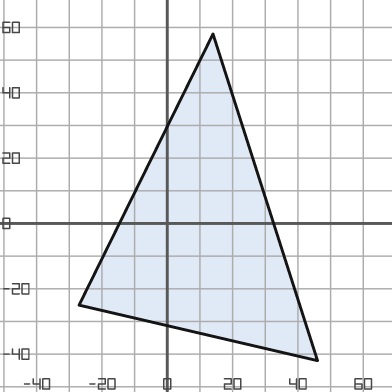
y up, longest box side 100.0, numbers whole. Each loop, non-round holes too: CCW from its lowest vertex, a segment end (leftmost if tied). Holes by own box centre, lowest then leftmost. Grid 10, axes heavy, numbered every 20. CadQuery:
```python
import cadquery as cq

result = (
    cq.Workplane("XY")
    .moveTo(46.0, -42.0)
    .lineTo(14.0, 58.0)
    .lineTo(-27.0, -25.0)
    .close()
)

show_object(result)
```